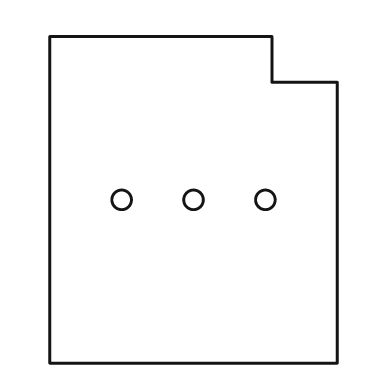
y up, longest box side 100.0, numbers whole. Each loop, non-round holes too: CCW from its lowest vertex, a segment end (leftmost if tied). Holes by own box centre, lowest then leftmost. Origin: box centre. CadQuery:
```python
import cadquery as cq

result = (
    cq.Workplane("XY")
    .moveTo(-44.0, -50.0)
    .lineTo(44.0, -50.0)
    .lineTo(44.0, 36.0)
    .lineTo(24.0, 36.0)
    .lineTo(24.0, 50.0)
    .lineTo(-44.0, 50.0)
    .close()
    .moveTo(-22.0, 0.0)
    .circle(3.0)
    .moveTo(0.0, 0.0)
    .circle(3.0)
    .moveTo(22.0, 0.0)
    .circle(3.0)
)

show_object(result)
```